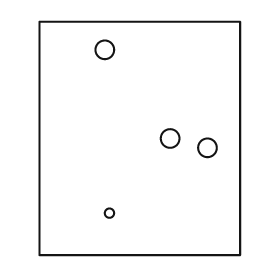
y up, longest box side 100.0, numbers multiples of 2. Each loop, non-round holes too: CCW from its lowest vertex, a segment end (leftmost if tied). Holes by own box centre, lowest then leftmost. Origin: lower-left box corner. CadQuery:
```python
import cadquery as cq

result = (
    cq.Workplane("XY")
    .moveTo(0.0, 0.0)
    .lineTo(86.0, 0.0)
    .lineTo(86.0, 100.0)
    .lineTo(0.0, 100.0)
    .close()
    .moveTo(30.0, 18.0)
    .circle(2.0)
    .moveTo(72.0, 46.0)
    .circle(4.0)
    .moveTo(56.0, 50.0)
    .circle(4.0)
    .moveTo(28.0, 88.0)
    .circle(4.0)
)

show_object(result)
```